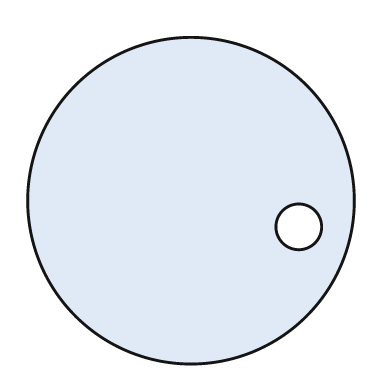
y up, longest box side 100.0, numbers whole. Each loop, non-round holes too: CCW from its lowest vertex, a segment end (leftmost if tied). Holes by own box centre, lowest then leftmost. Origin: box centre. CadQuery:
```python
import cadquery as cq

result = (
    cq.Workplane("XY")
    .moveTo(0.0, 0.0)
    .circle(50.0)
    .moveTo(33.0, -8.0)
    .circle(7.0)
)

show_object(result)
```